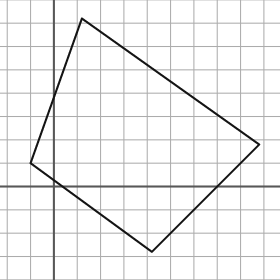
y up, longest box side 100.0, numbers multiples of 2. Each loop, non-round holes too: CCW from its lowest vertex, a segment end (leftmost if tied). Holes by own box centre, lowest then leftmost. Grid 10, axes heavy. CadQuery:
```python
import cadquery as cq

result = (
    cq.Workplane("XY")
    .moveTo(42.0, -28.0)
    .lineTo(88.0, 18.0)
    .lineTo(12.0, 72.0)
    .lineTo(-10.0, 10.0)
    .close()
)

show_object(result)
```